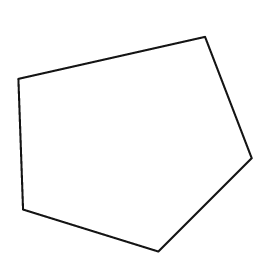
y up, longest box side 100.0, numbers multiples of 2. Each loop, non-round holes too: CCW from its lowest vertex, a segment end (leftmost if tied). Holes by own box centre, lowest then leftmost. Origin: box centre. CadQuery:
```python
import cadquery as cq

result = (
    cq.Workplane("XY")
    .moveTo(10.0, -46.0)
    .lineTo(50.0, -6.0)
    .lineTo(30.0, 46.0)
    .lineTo(-50.0, 28.0)
    .lineTo(-48.0, -28.0)
    .close()
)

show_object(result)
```